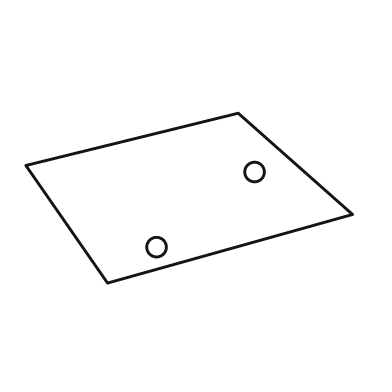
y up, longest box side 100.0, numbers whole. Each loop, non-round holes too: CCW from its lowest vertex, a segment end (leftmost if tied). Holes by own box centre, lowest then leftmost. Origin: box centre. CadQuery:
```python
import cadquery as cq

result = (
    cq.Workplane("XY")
    .moveTo(-25.0, -26.0)
    .lineTo(50.0, -5.0)
    .lineTo(15.0, 26.0)
    .lineTo(-50.0, 10.0)
    .close()
    .moveTo(-10.0, -15.0)
    .circle(3.0)
    .moveTo(20.0, 8.0)
    .circle(3.0)
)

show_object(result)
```